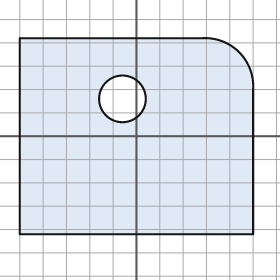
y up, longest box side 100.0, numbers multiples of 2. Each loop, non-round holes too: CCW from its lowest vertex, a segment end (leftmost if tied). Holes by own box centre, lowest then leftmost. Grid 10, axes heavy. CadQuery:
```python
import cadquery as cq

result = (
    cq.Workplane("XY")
    .moveTo(-50.0, -42.0)
    .lineTo(50.0, -42.0)
    .lineTo(50.0, 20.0)
    .threePointArc((44.0, 36.0), (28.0, 42.0))
    .lineTo(-50.0, 42.0)
    .close()
    .moveTo(-6.0, 16.0)
    .circle(10.0)
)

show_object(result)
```